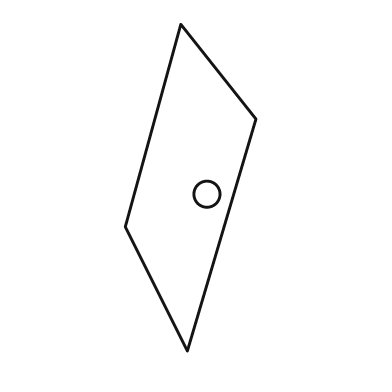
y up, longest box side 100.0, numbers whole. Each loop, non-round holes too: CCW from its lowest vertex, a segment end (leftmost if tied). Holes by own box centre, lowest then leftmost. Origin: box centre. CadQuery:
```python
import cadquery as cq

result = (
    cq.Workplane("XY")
    .moveTo(-1.0, -50.0)
    .lineTo(20.0, 21.0)
    .lineTo(-3.0, 50.0)
    .lineTo(-20.0, -12.0)
    .close()
    .moveTo(5.0, -2.0)
    .circle(4.0)
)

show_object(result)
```